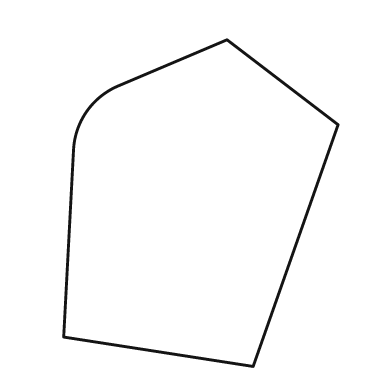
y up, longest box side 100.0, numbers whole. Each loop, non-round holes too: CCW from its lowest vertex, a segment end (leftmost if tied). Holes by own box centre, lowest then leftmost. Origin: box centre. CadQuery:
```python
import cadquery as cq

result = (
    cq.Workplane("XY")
    .moveTo(16.0, -50.0)
    .lineTo(42.0, 24.0)
    .lineTo(8.0, 50.0)
    .lineTo(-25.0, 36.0)
    .threePointArc((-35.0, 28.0), (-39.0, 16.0))
    .lineTo(-42.0, -41.0)
    .close()
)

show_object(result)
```